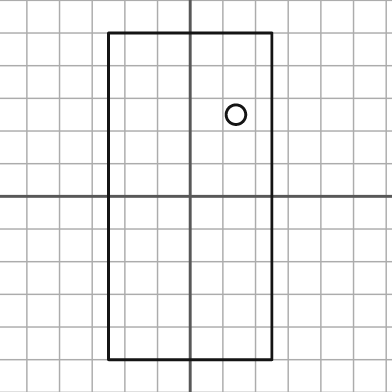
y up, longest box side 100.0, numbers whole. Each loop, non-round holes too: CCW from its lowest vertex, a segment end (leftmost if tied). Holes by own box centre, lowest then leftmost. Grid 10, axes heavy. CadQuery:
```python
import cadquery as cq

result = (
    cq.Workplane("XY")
    .moveTo(-25.0, -50.0)
    .lineTo(25.0, -50.0)
    .lineTo(25.0, 50.0)
    .lineTo(-25.0, 50.0)
    .close()
    .moveTo(14.0, 25.0)
    .circle(3.0)
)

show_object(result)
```